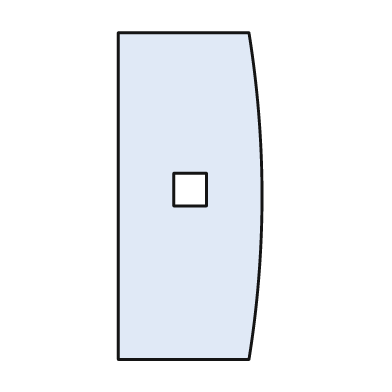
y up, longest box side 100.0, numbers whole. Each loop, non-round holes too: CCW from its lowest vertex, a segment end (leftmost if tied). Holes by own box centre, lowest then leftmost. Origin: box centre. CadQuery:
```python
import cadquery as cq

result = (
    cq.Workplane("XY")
    .moveTo(-22.0, -50.0)
    .lineTo(18.0, -50.0)
    .threePointArc((22.0, 0.0), (18.0, 50.0))
    .lineTo(-22.0, 50.0)
    .close()
    .moveTo(-5.0, -3.0)
    .lineTo(5.0, -3.0)
    .lineTo(5.0, 7.0)
    .lineTo(-5.0, 7.0)
    .close()
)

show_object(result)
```